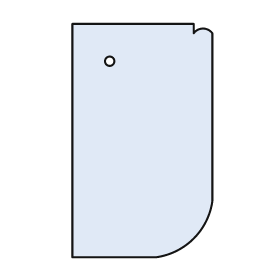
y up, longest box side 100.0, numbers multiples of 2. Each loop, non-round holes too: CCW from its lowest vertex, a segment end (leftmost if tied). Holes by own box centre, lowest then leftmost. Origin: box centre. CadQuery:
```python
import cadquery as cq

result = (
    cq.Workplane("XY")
    .moveTo(-30.0, -50.0)
    .lineTo(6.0, -50.0)
    .threePointArc((22.0, -42.0), (30.0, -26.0))
    .lineTo(30.0, 46.0)
    .threePointArc((26.0, 48.0), (22.0, 46.0))
    .lineTo(22.0, 50.0)
    .lineTo(-30.0, 50.0)
    .close()
    .moveTo(-14.0, 34.0)
    .circle(2.0)
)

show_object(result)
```